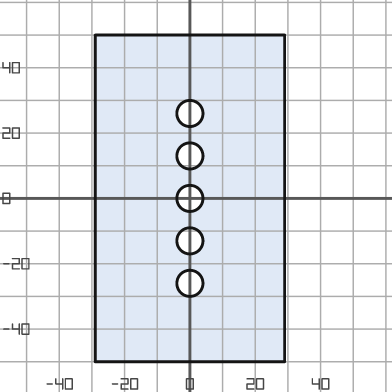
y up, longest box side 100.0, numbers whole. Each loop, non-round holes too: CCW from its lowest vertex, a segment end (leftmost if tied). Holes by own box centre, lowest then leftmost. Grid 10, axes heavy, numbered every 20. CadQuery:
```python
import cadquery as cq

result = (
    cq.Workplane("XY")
    .moveTo(-29.0, -50.0)
    .lineTo(29.0, -50.0)
    .lineTo(29.0, 50.0)
    .lineTo(-29.0, 50.0)
    .close()
    .moveTo(0.0, -26.0)
    .circle(4.0)
    .moveTo(0.0, -13.0)
    .circle(4.0)
    .moveTo(0.0, 0.0)
    .circle(4.0)
    .moveTo(0.0, 13.0)
    .circle(4.0)
    .moveTo(0.0, 26.0)
    .circle(4.0)
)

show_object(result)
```